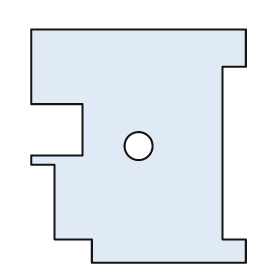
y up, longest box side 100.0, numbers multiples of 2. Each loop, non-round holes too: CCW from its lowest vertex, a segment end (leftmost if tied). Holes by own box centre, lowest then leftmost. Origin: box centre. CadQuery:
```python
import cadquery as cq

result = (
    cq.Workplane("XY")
    .moveTo(-20.0, -50.0)
    .lineTo(46.0, -50.0)
    .lineTo(46.0, -40.0)
    .lineTo(36.0, -40.0)
    .lineTo(36.0, 34.0)
    .lineTo(46.0, 34.0)
    .lineTo(46.0, 50.0)
    .lineTo(-46.0, 50.0)
    .lineTo(-46.0, 18.0)
    .lineTo(-24.0, 18.0)
    .lineTo(-24.0, -4.0)
    .lineTo(-46.0, -4.0)
    .lineTo(-46.0, -8.0)
    .lineTo(-36.0, -8.0)
    .lineTo(-36.0, -40.0)
    .lineTo(-20.0, -40.0)
    .close()
    .moveTo(0.0, 0.0)
    .circle(6.0)
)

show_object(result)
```